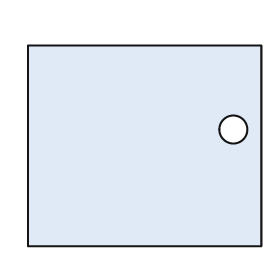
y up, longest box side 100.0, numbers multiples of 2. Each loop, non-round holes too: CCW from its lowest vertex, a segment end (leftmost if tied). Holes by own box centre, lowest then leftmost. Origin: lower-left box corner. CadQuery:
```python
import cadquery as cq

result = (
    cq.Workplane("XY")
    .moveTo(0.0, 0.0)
    .lineTo(100.0, 0.0)
    .lineTo(100.0, 86.0)
    .lineTo(0.0, 86.0)
    .close()
    .moveTo(88.0, 50.0)
    .circle(6.0)
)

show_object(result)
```